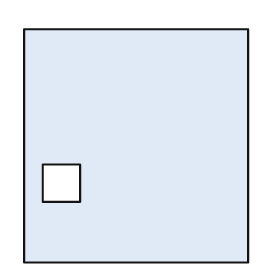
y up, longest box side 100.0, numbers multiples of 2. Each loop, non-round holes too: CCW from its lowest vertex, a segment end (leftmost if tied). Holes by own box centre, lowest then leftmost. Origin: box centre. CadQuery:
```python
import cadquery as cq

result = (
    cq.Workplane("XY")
    .moveTo(-48.0, -50.0)
    .lineTo(48.0, -50.0)
    .lineTo(48.0, 50.0)
    .lineTo(-48.0, 50.0)
    .close()
    .moveTo(-40.0, -24.0)
    .lineTo(-24.0, -24.0)
    .lineTo(-24.0, -8.0)
    .lineTo(-40.0, -8.0)
    .close()
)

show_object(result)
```